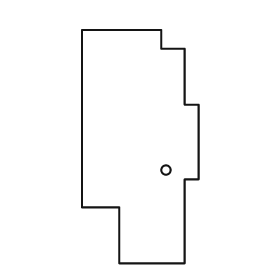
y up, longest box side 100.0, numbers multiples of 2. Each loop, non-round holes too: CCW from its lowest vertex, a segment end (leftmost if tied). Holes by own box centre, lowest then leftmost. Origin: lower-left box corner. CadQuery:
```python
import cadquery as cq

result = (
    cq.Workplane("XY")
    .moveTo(16.0, 0.0)
    .lineTo(44.0, 0.0)
    .lineTo(44.0, 36.0)
    .lineTo(50.0, 36.0)
    .lineTo(50.0, 68.0)
    .lineTo(44.0, 68.0)
    .lineTo(44.0, 92.0)
    .lineTo(34.0, 92.0)
    .lineTo(34.0, 100.0)
    .lineTo(0.0, 100.0)
    .lineTo(0.0, 24.0)
    .lineTo(16.0, 24.0)
    .close()
    .moveTo(36.0, 40.0)
    .circle(2.0)
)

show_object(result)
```